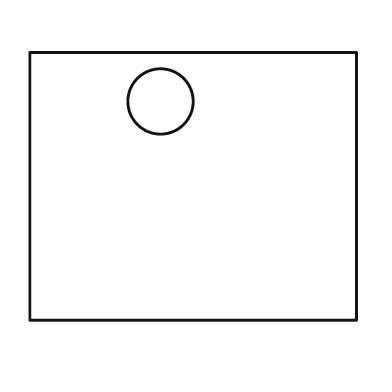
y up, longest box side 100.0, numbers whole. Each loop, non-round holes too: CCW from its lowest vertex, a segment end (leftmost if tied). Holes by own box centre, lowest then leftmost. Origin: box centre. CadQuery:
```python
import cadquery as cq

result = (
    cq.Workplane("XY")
    .moveTo(-50.0, -41.0)
    .lineTo(50.0, -41.0)
    .lineTo(50.0, 41.0)
    .lineTo(-50.0, 41.0)
    .close()
    .moveTo(-10.0, 26.0)
    .circle(10.0)
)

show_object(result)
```